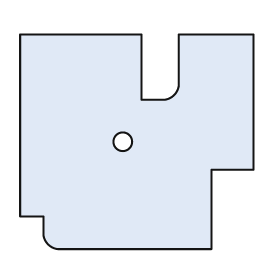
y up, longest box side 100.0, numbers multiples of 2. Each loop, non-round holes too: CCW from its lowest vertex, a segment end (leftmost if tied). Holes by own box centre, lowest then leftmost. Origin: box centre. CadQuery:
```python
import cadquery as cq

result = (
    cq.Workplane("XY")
    .moveTo(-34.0, -46.0)
    .lineTo(32.0, -46.0)
    .lineTo(32.0, -12.0)
    .lineTo(50.0, -12.0)
    .lineTo(50.0, 46.0)
    .lineTo(18.0, 46.0)
    .lineTo(18.0, 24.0)
    .threePointArc((16.0, 20.0), (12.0, 18.0))
    .lineTo(2.0, 18.0)
    .lineTo(2.0, 46.0)
    .lineTo(-50.0, 46.0)
    .lineTo(-50.0, -32.0)
    .lineTo(-40.0, -32.0)
    .lineTo(-40.0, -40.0)
    .threePointArc((-38.0, -44.0), (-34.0, -46.0))
    .close()
    .moveTo(-6.0, 0.0)
    .circle(4.0)
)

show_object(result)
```